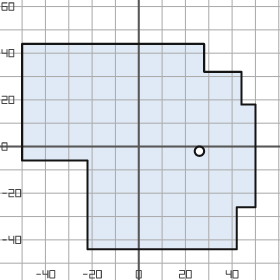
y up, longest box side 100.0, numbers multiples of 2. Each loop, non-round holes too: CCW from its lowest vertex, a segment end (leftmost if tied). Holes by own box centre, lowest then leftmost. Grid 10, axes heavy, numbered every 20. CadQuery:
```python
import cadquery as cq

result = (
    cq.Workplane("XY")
    .moveTo(-22.0, -44.0)
    .lineTo(42.0, -44.0)
    .lineTo(42.0, -26.0)
    .lineTo(50.0, -26.0)
    .lineTo(50.0, 18.0)
    .lineTo(44.0, 18.0)
    .lineTo(44.0, 32.0)
    .lineTo(28.0, 32.0)
    .lineTo(28.0, 44.0)
    .lineTo(-50.0, 44.0)
    .lineTo(-50.0, -6.0)
    .lineTo(-22.0, -6.0)
    .close()
    .moveTo(26.0, -2.0)
    .circle(2.0)
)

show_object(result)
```